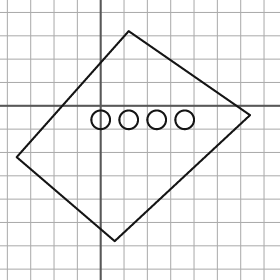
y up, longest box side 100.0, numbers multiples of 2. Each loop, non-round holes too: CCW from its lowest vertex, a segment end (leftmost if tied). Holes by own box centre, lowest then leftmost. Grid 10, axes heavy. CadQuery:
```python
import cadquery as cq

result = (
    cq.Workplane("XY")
    .moveTo(6.0, -58.0)
    .lineTo(64.0, -4.0)
    .lineTo(12.0, 32.0)
    .lineTo(-36.0, -22.0)
    .close()
    .moveTo(0.0, -6.0)
    .circle(4.0)
    .moveTo(12.0, -6.0)
    .circle(4.0)
    .moveTo(24.0, -6.0)
    .circle(4.0)
    .moveTo(36.0, -6.0)
    .circle(4.0)
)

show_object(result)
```